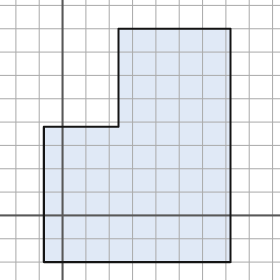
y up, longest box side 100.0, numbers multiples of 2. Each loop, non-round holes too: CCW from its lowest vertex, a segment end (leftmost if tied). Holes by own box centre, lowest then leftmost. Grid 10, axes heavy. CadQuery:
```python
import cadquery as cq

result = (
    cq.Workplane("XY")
    .moveTo(-8.0, -20.0)
    .lineTo(72.0, -20.0)
    .lineTo(72.0, 80.0)
    .lineTo(24.0, 80.0)
    .lineTo(24.0, 38.0)
    .lineTo(-8.0, 38.0)
    .close()
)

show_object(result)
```